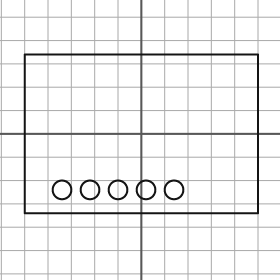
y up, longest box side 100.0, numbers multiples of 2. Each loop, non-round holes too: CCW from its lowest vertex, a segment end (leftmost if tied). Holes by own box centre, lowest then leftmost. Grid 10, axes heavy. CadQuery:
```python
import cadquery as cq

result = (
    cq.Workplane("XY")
    .moveTo(-50.0, -34.0)
    .lineTo(50.0, -34.0)
    .lineTo(50.0, 34.0)
    .lineTo(-50.0, 34.0)
    .close()
    .moveTo(-34.0, -24.0)
    .circle(4.0)
    .moveTo(-22.0, -24.0)
    .circle(4.0)
    .moveTo(-10.0, -24.0)
    .circle(4.0)
    .moveTo(2.0, -24.0)
    .circle(4.0)
    .moveTo(14.0, -24.0)
    .circle(4.0)
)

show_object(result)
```